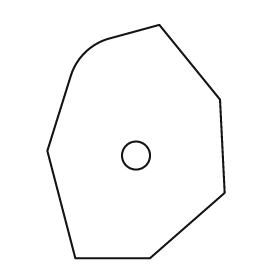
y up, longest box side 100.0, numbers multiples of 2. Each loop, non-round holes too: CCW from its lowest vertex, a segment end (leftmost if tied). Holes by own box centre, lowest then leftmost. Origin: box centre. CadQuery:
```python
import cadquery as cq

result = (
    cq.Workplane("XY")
    .moveTo(-26.0, -50.0)
    .lineTo(6.0, -50.0)
    .lineTo(38.0, -22.0)
    .lineTo(36.0, 18.0)
    .lineTo(10.0, 50.0)
    .lineTo(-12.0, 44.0)
    .threePointArc((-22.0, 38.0), (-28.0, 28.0))
    .lineTo(-38.0, -4.0)
    .close()
    .moveTo(0.0, -6.0)
    .circle(6.0)
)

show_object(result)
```